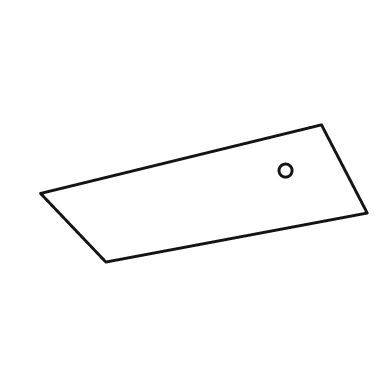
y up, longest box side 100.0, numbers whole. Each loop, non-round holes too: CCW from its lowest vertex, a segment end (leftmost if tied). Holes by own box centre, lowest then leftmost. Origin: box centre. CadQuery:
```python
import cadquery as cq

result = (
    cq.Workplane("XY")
    .moveTo(-30.0, -21.0)
    .lineTo(50.0, -6.0)
    .lineTo(36.0, 21.0)
    .lineTo(-50.0, 0.0)
    .close()
    .moveTo(25.0, 7.0)
    .circle(2.0)
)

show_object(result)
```